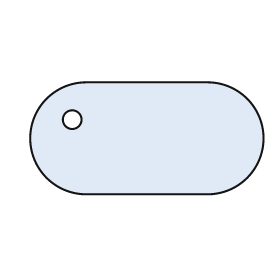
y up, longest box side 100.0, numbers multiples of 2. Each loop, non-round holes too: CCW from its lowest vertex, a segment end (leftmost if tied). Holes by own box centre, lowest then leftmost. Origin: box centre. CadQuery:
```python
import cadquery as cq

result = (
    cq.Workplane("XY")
    .moveTo(-26.0, -24.0)
    .lineTo(26.0, -24.0)
    .threePointArc((50.0, 0.0), (26.0, 24.0))
    .lineTo(-26.0, 24.0)
    .threePointArc((-50.0, 0.0), (-26.0, -24.0))
    .close()
    .moveTo(-32.0, 8.0)
    .circle(4.0)
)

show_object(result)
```